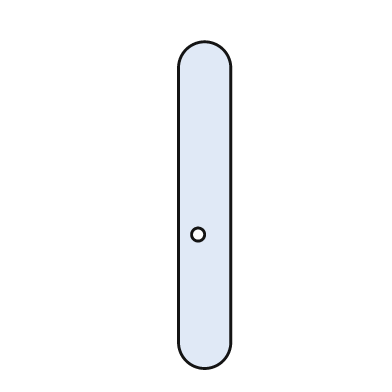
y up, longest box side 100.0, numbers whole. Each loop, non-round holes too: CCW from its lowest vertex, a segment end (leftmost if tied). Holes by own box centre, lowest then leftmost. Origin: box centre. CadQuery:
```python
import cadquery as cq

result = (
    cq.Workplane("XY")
    .moveTo(-8.0, -42.0)
    .threePointArc((0.0, -50.0), (8.0, -42.0))
    .lineTo(8.0, 42.0)
    .threePointArc((0.0, 50.0), (-8.0, 42.0))
    .close()
    .moveTo(-2.0, -9.0)
    .circle(2.0)
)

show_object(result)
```